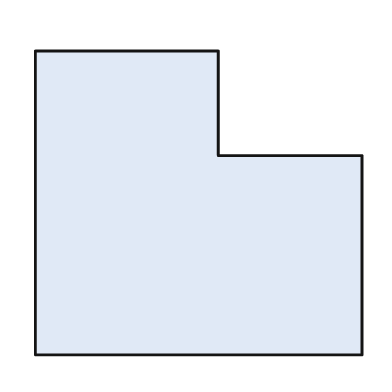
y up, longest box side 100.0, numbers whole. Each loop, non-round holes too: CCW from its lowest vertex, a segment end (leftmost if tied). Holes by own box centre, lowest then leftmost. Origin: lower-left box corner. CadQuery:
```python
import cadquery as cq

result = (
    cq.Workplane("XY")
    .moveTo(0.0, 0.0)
    .lineTo(100.0, 0.0)
    .lineTo(100.0, 61.0)
    .lineTo(56.0, 61.0)
    .lineTo(56.0, 93.0)
    .lineTo(0.0, 93.0)
    .close()
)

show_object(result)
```